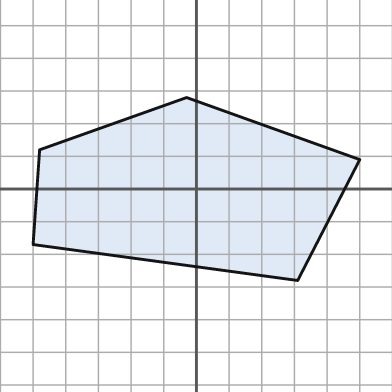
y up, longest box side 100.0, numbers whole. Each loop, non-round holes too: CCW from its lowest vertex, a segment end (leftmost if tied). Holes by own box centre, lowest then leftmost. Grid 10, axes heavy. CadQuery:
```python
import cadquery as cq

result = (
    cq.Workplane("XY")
    .moveTo(31.0, -28.0)
    .lineTo(50.0, 9.0)
    .lineTo(-3.0, 28.0)
    .lineTo(-48.0, 12.0)
    .lineTo(-50.0, -17.0)
    .close()
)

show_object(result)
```